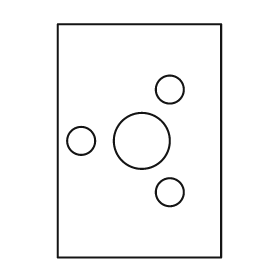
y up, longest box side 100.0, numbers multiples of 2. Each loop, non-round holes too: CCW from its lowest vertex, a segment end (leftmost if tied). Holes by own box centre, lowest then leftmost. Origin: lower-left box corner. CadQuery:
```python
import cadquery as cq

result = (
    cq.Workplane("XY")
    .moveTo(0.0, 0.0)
    .lineTo(70.0, 0.0)
    .lineTo(70.0, 100.0)
    .lineTo(0.0, 100.0)
    .close()
    .moveTo(48.0, 28.0)
    .circle(6.0)
    .moveTo(10.0, 50.0)
    .circle(6.0)
    .moveTo(36.0, 50.0)
    .circle(12.0)
    .moveTo(48.0, 72.0)
    .circle(6.0)
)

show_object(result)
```